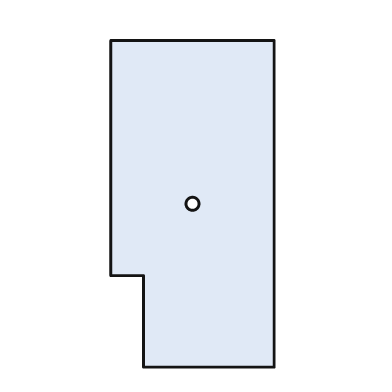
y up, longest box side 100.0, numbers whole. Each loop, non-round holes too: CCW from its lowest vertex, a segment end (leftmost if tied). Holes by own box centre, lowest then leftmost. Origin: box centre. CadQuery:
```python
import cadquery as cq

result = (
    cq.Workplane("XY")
    .moveTo(-15.0, -50.0)
    .lineTo(25.0, -50.0)
    .lineTo(25.0, 50.0)
    .lineTo(-25.0, 50.0)
    .lineTo(-25.0, -22.0)
    .lineTo(-15.0, -22.0)
    .close()
    .moveTo(0.0, 0.0)
    .circle(2.0)
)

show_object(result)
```